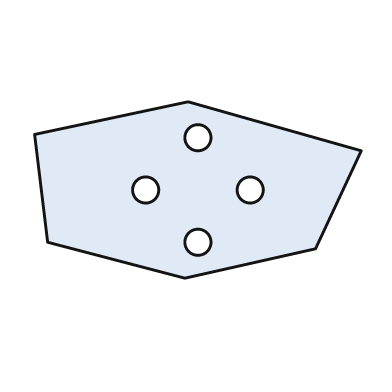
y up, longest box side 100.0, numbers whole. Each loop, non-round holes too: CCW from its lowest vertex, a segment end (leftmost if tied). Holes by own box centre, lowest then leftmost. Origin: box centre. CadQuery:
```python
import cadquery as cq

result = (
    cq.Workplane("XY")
    .moveTo(-4.0, -27.0)
    .lineTo(36.0, -18.0)
    .lineTo(50.0, 12.0)
    .lineTo(-3.0, 27.0)
    .lineTo(-50.0, 17.0)
    .lineTo(-46.0, -16.0)
    .close()
    .moveTo(0.0, -16.0)
    .circle(4.0)
    .moveTo(-16.0, 0.0)
    .circle(4.0)
    .moveTo(16.0, 0.0)
    .circle(4.0)
    .moveTo(0.0, 16.0)
    .circle(4.0)
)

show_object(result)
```